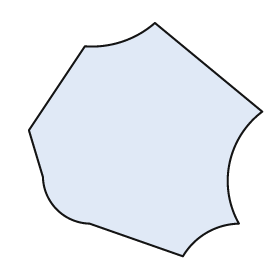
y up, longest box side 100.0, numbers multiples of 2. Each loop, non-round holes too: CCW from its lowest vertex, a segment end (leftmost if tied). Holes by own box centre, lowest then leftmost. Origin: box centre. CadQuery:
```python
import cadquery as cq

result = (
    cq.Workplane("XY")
    .moveTo(16.0, -50.0)
    .threePointArc((26.0, -40.0), (40.0, -36.0))
    .threePointArc((36.0, -10.0), (50.0, 12.0))
    .lineTo(4.0, 50.0)
    .threePointArc((-10.0, 42.0), (-26.0, 40.0))
    .lineTo(-50.0, 4.0)
    .lineTo(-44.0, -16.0)
    .threePointArc((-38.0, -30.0), (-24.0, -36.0))
    .close()
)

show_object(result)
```